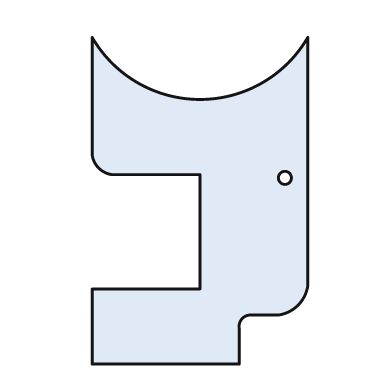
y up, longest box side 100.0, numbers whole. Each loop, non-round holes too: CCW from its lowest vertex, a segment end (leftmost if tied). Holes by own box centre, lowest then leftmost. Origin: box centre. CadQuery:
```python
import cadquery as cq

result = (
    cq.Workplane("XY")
    .moveTo(-33.0, -50.0)
    .lineTo(12.0, -50.0)
    .lineTo(12.0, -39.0)
    .threePointArc((13.0, -36.0), (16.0, -35.0))
    .lineTo(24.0, -35.0)
    .threePointArc((30.0, -32.0), (33.0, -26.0))
    .lineTo(33.0, 50.0)
    .threePointArc((0.0, 31.0), (-33.0, 50.0))
    .lineTo(-33.0, 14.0)
    .threePointArc((-31.0, 10.0), (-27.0, 8.0))
    .lineTo(0.0, 8.0)
    .lineTo(0.0, -27.0)
    .lineTo(-33.0, -27.0)
    .close()
    .moveTo(26.0, 7.0)
    .circle(2.0)
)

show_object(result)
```